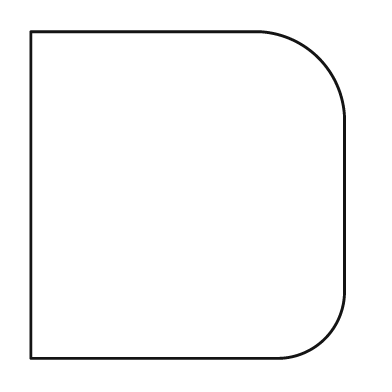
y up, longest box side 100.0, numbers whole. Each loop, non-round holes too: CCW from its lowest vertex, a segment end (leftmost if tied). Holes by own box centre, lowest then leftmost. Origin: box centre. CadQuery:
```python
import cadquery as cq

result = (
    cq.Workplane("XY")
    .moveTo(-48.0, -50.0)
    .lineTo(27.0, -50.0)
    .threePointArc((42.0, -44.0), (48.0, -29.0))
    .lineTo(48.0, 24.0)
    .threePointArc((40.0, 42.0), (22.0, 50.0))
    .lineTo(-48.0, 50.0)
    .close()
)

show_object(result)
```